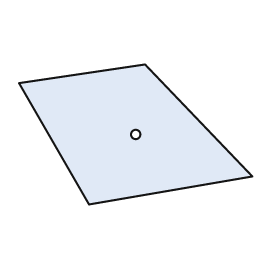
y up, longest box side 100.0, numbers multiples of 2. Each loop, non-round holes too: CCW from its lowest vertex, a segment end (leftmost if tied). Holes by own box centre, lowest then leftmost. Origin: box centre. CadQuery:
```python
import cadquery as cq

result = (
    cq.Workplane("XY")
    .moveTo(-20.0, -30.0)
    .lineTo(50.0, -18.0)
    .lineTo(4.0, 30.0)
    .lineTo(-50.0, 22.0)
    .close()
    .moveTo(0.0, 0.0)
    .circle(2.0)
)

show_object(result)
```